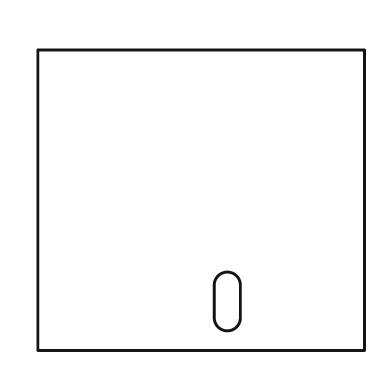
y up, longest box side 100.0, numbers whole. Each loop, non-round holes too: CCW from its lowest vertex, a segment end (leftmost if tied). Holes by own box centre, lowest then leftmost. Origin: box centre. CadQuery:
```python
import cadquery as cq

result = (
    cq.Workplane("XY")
    .moveTo(-50.0, -46.0)
    .lineTo(50.0, -46.0)
    .lineTo(50.0, 46.0)
    .lineTo(-50.0, 46.0)
    .close()
    .moveTo(4.0, -36.0)
    .threePointArc((8.0, -40.0), (12.0, -36.0))
    .lineTo(12.0, -26.0)
    .threePointArc((8.0, -22.0), (4.0, -26.0))
    .close()
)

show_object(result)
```